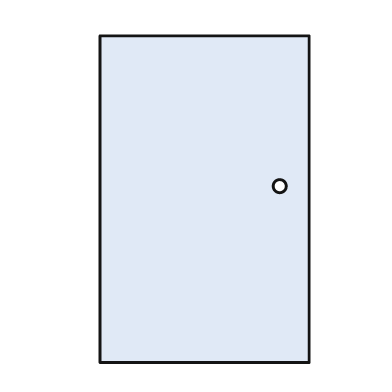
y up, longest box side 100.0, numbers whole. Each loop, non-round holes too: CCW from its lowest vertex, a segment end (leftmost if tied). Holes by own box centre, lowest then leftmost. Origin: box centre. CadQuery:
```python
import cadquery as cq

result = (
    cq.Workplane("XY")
    .moveTo(-32.0, -50.0)
    .lineTo(32.0, -50.0)
    .lineTo(32.0, 50.0)
    .lineTo(-32.0, 50.0)
    .close()
    .moveTo(23.0, 4.0)
    .circle(2.0)
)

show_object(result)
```